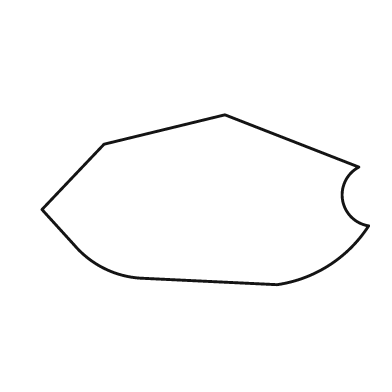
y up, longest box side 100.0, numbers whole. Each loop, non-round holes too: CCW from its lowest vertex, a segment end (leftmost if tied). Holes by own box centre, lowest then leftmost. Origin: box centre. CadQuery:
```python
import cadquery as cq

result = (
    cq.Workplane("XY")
    .moveTo(22.0, -26.0)
    .threePointArc((38.0, -20.0), (50.0, -8.0))
    .threePointArc((42.0, 0.0), (47.0, 10.0))
    .lineTo(6.0, 26.0)
    .lineTo(-31.0, 17.0)
    .lineTo(-50.0, -3.0)
    .lineTo(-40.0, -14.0)
    .threePointArc((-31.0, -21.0), (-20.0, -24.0))
    .close()
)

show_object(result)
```